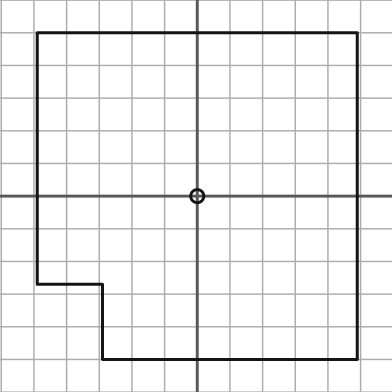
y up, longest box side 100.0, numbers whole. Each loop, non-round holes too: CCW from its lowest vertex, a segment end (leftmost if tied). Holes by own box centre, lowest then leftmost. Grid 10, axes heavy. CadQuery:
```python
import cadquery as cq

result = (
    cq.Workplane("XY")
    .moveTo(-29.0, -50.0)
    .lineTo(49.0, -50.0)
    .lineTo(49.0, 50.0)
    .lineTo(-49.0, 50.0)
    .lineTo(-49.0, -27.0)
    .lineTo(-29.0, -27.0)
    .close()
    .moveTo(0.0, 0.0)
    .circle(2.0)
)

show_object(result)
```